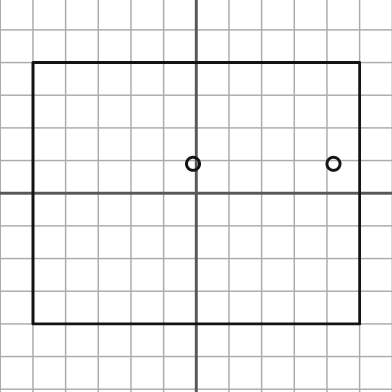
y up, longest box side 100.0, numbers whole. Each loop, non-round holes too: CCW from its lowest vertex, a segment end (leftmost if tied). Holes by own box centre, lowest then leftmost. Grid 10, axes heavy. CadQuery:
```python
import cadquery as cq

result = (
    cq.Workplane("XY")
    .moveTo(-50.0, -40.0)
    .lineTo(50.0, -40.0)
    .lineTo(50.0, 40.0)
    .lineTo(-50.0, 40.0)
    .close()
    .moveTo(-1.0, 9.0)
    .circle(2.0)
    .moveTo(42.0, 9.0)
    .circle(2.0)
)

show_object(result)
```